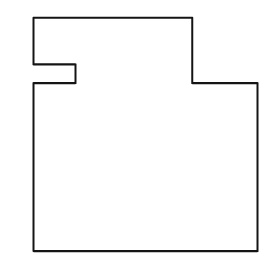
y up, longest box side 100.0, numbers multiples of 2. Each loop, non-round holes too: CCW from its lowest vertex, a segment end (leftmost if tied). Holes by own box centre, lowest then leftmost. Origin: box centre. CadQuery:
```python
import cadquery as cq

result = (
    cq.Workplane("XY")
    .moveTo(-48.0, -50.0)
    .lineTo(48.0, -50.0)
    .lineTo(48.0, 22.0)
    .lineTo(20.0, 22.0)
    .lineTo(20.0, 50.0)
    .lineTo(-48.0, 50.0)
    .lineTo(-48.0, 30.0)
    .lineTo(-30.0, 30.0)
    .lineTo(-30.0, 22.0)
    .lineTo(-48.0, 22.0)
    .close()
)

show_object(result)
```